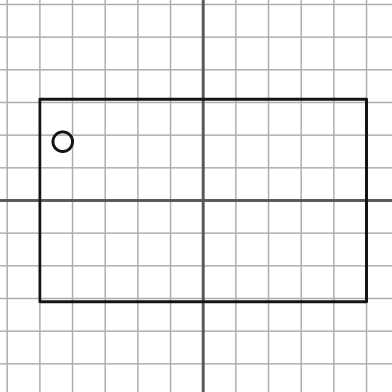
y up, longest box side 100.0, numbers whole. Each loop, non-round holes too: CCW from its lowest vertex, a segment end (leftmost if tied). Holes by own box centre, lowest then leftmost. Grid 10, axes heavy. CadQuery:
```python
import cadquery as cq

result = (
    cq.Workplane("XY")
    .moveTo(-50.0, -31.0)
    .lineTo(50.0, -31.0)
    .lineTo(50.0, 31.0)
    .lineTo(-50.0, 31.0)
    .close()
    .moveTo(-43.0, 18.0)
    .circle(3.0)
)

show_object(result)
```